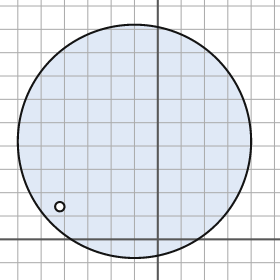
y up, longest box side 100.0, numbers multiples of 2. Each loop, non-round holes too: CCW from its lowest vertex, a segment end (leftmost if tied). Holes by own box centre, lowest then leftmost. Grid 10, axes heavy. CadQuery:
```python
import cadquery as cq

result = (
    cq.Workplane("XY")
    .moveTo(-10.0, 42.0)
    .circle(50.0)
    .moveTo(-42.0, 14.0)
    .circle(2.0)
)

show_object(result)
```